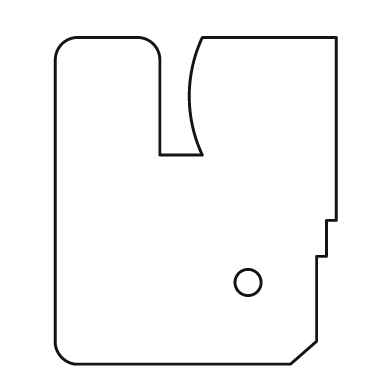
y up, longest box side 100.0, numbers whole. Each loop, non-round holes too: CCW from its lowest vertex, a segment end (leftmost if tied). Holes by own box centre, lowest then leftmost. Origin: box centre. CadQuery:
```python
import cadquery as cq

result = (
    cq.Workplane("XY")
    .moveTo(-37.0, -50.0)
    .lineTo(29.0, -50.0)
    .lineTo(37.0, -43.0)
    .lineTo(37.0, -17.0)
    .lineTo(40.0, -17.0)
    .lineTo(40.0, -6.0)
    .lineTo(43.0, -6.0)
    .lineTo(43.0, 50.0)
    .lineTo(2.0, 50.0)
    .threePointArc((-2.0, 32.0), (2.0, 14.0))
    .lineTo(-11.0, 14.0)
    .lineTo(-11.0, 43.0)
    .threePointArc((-13.0, 48.0), (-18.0, 50.0))
    .lineTo(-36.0, 50.0)
    .threePointArc((-41.0, 48.0), (-43.0, 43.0))
    .lineTo(-43.0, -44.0)
    .threePointArc((-41.0, -48.0), (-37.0, -50.0))
    .close()
    .moveTo(16.0, -25.0)
    .circle(4.0)
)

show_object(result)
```